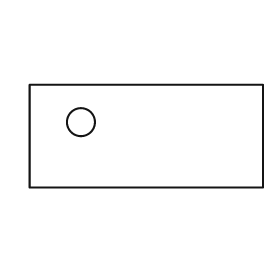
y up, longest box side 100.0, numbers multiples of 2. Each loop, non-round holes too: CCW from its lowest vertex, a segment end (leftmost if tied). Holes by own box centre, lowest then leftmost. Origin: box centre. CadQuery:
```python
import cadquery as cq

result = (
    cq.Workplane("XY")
    .moveTo(-50.0, -22.0)
    .lineTo(50.0, -22.0)
    .lineTo(50.0, 22.0)
    .lineTo(-50.0, 22.0)
    .close()
    .moveTo(-28.0, 6.0)
    .circle(6.0)
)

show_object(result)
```